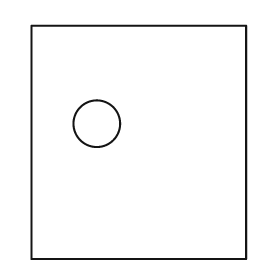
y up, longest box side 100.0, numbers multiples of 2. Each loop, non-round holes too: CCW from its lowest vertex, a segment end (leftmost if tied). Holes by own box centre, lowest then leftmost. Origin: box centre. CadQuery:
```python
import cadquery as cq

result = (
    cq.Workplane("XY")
    .moveTo(-46.0, -50.0)
    .lineTo(46.0, -50.0)
    .lineTo(46.0, 50.0)
    .lineTo(-46.0, 50.0)
    .close()
    .moveTo(-18.0, 8.0)
    .circle(10.0)
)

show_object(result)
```